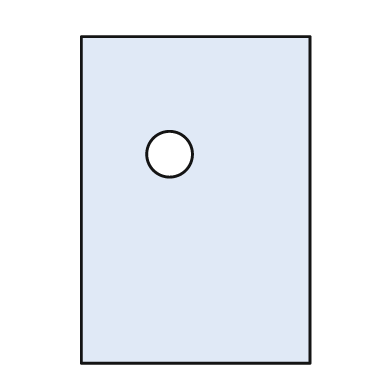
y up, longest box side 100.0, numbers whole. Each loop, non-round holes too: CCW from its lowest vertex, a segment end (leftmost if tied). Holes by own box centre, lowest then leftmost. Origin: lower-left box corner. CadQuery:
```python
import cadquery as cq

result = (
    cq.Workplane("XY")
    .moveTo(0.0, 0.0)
    .lineTo(70.0, 0.0)
    .lineTo(70.0, 100.0)
    .lineTo(0.0, 100.0)
    .close()
    .moveTo(27.0, 64.0)
    .circle(7.0)
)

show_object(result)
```